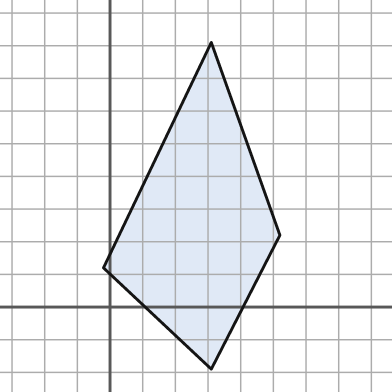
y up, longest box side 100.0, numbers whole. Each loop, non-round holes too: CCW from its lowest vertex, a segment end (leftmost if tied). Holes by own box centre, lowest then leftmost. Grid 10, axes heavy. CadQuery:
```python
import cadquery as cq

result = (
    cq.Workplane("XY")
    .moveTo(31.0, -19.0)
    .lineTo(52.0, 22.0)
    .lineTo(31.0, 81.0)
    .lineTo(-2.0, 12.0)
    .close()
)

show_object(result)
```